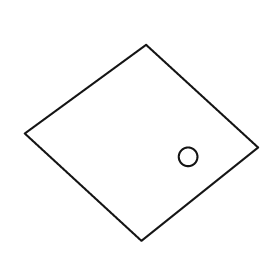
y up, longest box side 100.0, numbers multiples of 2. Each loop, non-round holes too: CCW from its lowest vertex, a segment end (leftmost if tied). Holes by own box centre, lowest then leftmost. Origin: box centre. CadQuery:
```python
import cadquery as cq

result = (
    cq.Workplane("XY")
    .moveTo(0.0, -42.0)
    .lineTo(50.0, -2.0)
    .lineTo(2.0, 42.0)
    .lineTo(-50.0, 4.0)
    .close()
    .moveTo(20.0, -6.0)
    .circle(4.0)
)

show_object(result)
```